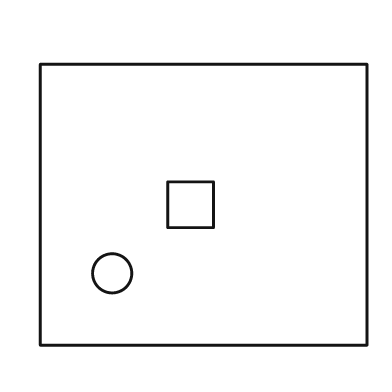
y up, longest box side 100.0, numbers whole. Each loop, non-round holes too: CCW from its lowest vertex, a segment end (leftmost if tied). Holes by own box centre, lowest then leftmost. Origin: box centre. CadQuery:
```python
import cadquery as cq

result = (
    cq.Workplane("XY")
    .moveTo(-50.0, -43.0)
    .lineTo(50.0, -43.0)
    .lineTo(50.0, 43.0)
    .lineTo(-50.0, 43.0)
    .close()
    .moveTo(-28.0, -21.0)
    .circle(6.0)
    .moveTo(-11.0, -7.0)
    .lineTo(3.0, -7.0)
    .lineTo(3.0, 7.0)
    .lineTo(-11.0, 7.0)
    .close()
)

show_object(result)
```